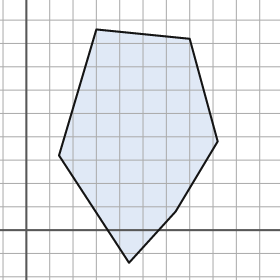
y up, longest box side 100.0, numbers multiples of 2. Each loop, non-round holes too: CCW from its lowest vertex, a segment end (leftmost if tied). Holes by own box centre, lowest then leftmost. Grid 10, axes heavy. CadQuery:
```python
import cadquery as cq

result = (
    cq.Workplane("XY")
    .moveTo(44.0, -14.0)
    .lineTo(64.0, 8.0)
    .lineTo(82.0, 38.0)
    .lineTo(70.0, 82.0)
    .lineTo(30.0, 86.0)
    .lineTo(14.0, 32.0)
    .close()
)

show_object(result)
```